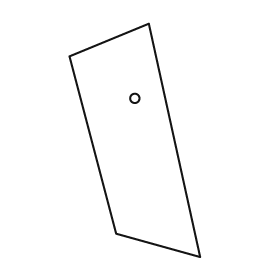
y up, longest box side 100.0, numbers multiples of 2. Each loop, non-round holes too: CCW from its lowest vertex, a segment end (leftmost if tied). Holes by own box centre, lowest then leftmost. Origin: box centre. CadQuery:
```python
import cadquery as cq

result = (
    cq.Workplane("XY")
    .moveTo(28.0, -50.0)
    .lineTo(6.0, 50.0)
    .lineTo(-28.0, 36.0)
    .lineTo(-8.0, -40.0)
    .close()
    .moveTo(0.0, 18.0)
    .circle(2.0)
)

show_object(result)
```